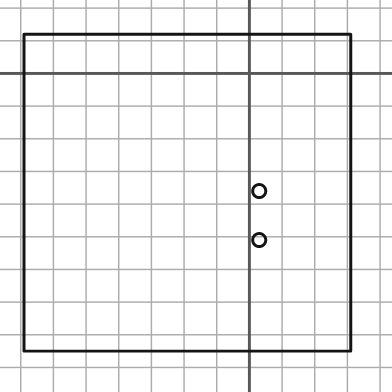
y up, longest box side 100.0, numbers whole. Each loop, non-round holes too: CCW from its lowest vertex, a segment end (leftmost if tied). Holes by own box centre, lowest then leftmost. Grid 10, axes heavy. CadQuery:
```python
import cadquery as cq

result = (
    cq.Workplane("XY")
    .moveTo(-69.0, -85.0)
    .lineTo(31.0, -85.0)
    .lineTo(31.0, 12.0)
    .lineTo(-69.0, 12.0)
    .close()
    .moveTo(3.0, -51.0)
    .circle(2.0)
    .moveTo(3.0, -36.0)
    .circle(2.0)
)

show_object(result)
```